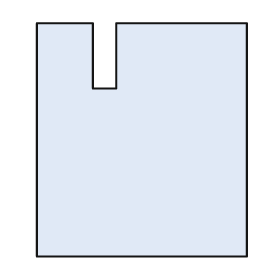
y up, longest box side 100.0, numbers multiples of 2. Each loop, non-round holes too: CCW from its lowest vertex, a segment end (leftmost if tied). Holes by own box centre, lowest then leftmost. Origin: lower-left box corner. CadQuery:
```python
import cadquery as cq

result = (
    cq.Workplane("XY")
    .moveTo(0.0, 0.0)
    .lineTo(90.0, 0.0)
    .lineTo(90.0, 100.0)
    .lineTo(34.0, 100.0)
    .lineTo(34.0, 72.0)
    .lineTo(24.0, 72.0)
    .lineTo(24.0, 100.0)
    .lineTo(0.0, 100.0)
    .close()
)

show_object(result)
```